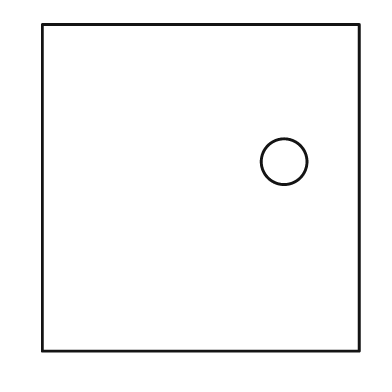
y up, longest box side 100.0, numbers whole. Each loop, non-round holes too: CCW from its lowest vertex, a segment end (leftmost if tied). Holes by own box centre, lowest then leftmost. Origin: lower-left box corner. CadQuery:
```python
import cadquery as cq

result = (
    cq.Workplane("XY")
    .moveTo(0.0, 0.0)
    .lineTo(97.0, 0.0)
    .lineTo(97.0, 100.0)
    .lineTo(0.0, 100.0)
    .close()
    .moveTo(74.0, 58.0)
    .circle(7.0)
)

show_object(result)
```